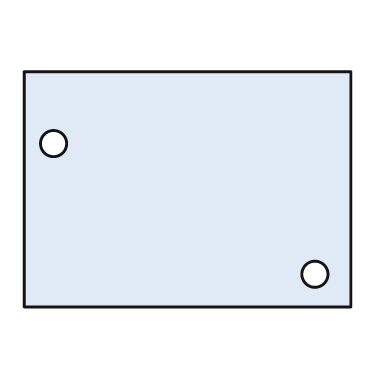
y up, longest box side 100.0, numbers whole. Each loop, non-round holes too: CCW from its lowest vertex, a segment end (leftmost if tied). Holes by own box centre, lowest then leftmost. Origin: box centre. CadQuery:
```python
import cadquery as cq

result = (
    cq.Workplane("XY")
    .moveTo(-50.0, -36.0)
    .lineTo(50.0, -36.0)
    .lineTo(50.0, 36.0)
    .lineTo(-50.0, 36.0)
    .close()
    .moveTo(39.0, -26.0)
    .circle(4.0)
    .moveTo(-41.0, 14.0)
    .circle(4.0)
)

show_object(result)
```